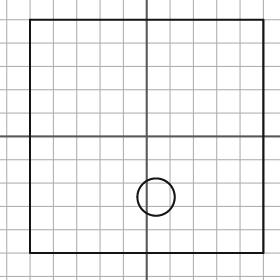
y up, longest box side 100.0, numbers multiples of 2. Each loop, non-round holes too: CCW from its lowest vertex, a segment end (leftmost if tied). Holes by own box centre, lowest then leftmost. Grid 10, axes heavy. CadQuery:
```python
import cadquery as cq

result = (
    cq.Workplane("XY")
    .moveTo(-50.0, -50.0)
    .lineTo(50.0, -50.0)
    .lineTo(50.0, 50.0)
    .lineTo(-50.0, 50.0)
    .close()
    .moveTo(4.0, -26.0)
    .circle(8.0)
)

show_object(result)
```